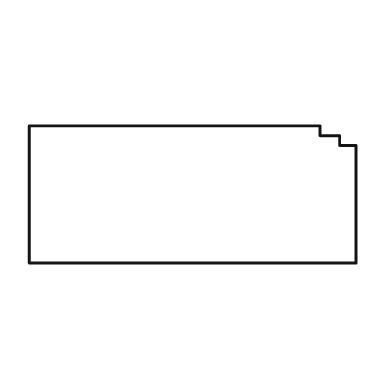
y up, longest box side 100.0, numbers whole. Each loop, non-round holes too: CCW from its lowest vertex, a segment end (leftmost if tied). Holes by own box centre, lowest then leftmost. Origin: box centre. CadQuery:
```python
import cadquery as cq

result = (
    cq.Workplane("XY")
    .moveTo(-50.0, -21.0)
    .lineTo(50.0, -21.0)
    .lineTo(50.0, 15.0)
    .lineTo(45.0, 15.0)
    .lineTo(45.0, 18.0)
    .lineTo(39.0, 18.0)
    .lineTo(39.0, 21.0)
    .lineTo(-50.0, 21.0)
    .close()
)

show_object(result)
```